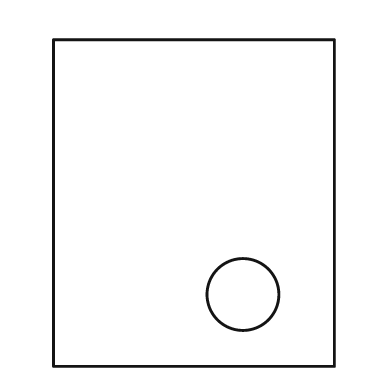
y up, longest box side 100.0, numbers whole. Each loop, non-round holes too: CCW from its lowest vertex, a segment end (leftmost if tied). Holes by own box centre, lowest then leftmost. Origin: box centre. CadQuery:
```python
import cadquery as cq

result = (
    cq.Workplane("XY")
    .moveTo(-43.0, -50.0)
    .lineTo(43.0, -50.0)
    .lineTo(43.0, 50.0)
    .lineTo(-43.0, 50.0)
    .close()
    .moveTo(15.0, -28.0)
    .circle(11.0)
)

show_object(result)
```